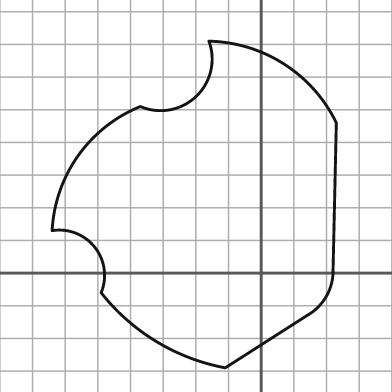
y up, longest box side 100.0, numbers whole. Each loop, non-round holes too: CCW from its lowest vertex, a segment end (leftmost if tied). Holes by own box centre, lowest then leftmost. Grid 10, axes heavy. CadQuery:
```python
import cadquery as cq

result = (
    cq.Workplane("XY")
    .moveTo(-11.0, -29.0)
    .lineTo(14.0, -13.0)
    .threePointArc((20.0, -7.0), (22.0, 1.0))
    .lineTo(23.0, 46.0)
    .threePointArc((7.0, 64.0), (-16.0, 71.0))
    .threePointArc((-20.0, 54.0), (-37.0, 51.0))
    .threePointArc((-56.0, 36.0), (-64.0, 13.0))
    .threePointArc((-51.0, 8.0), (-49.0, -6.0))
    .threePointArc((-32.0, -21.0), (-11.0, -29.0))
    .close()
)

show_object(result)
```